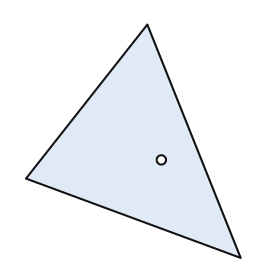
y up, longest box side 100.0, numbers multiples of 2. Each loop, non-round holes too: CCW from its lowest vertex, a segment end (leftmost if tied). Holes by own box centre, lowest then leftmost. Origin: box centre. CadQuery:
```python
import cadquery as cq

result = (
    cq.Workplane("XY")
    .moveTo(46.0, -50.0)
    .lineTo(6.0, 50.0)
    .lineTo(-46.0, -16.0)
    .close()
    .moveTo(12.0, -8.0)
    .circle(2.0)
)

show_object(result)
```